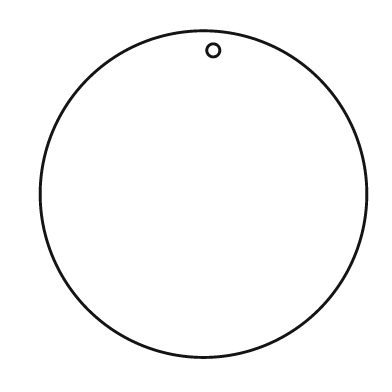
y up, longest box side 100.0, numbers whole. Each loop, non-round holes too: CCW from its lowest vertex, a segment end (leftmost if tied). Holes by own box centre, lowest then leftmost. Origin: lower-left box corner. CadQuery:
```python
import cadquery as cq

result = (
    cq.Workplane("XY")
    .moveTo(50.0, 50.0)
    .circle(50.0)
    .moveTo(53.0, 94.0)
    .circle(2.0)
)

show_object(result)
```